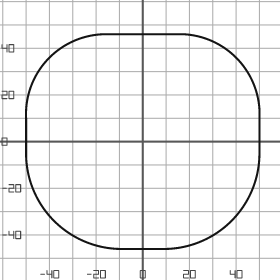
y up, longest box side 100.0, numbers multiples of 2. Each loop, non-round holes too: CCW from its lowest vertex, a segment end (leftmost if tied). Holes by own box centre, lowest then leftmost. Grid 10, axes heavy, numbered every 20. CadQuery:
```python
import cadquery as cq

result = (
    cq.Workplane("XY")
    .moveTo(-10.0, -46.0)
    .lineTo(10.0, -46.0)
    .threePointArc((38.0, -34.0), (50.0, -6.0))
    .lineTo(50.0, 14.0)
    .threePointArc((40.0, 36.0), (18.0, 46.0))
    .lineTo(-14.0, 46.0)
    .threePointArc((-40.0, 36.0), (-50.0, 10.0))
    .lineTo(-50.0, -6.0)
    .threePointArc((-38.0, -34.0), (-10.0, -46.0))
    .close()
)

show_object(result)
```